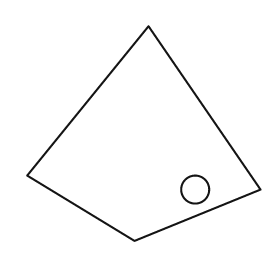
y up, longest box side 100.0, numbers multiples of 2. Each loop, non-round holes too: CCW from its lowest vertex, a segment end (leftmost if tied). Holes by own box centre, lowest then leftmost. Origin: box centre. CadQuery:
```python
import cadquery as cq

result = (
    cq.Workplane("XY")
    .moveTo(-4.0, -46.0)
    .lineTo(50.0, -24.0)
    .lineTo(2.0, 46.0)
    .lineTo(-50.0, -18.0)
    .close()
    .moveTo(22.0, -24.0)
    .circle(6.0)
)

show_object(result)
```